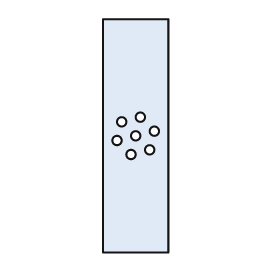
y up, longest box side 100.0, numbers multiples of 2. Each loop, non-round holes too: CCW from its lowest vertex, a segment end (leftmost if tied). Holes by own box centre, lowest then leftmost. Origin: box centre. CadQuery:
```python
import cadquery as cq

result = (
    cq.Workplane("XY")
    .moveTo(-14.0, -50.0)
    .lineTo(14.0, -50.0)
    .lineTo(14.0, 50.0)
    .lineTo(-14.0, 50.0)
    .close()
    .moveTo(-2.0, -8.0)
    .circle(2.0)
    .moveTo(6.0, -6.0)
    .circle(2.0)
    .moveTo(-8.0, -2.0)
    .circle(2.0)
    .moveTo(0.0, 0.0)
    .circle(2.0)
    .moveTo(8.0, 2.0)
    .circle(2.0)
    .moveTo(-6.0, 6.0)
    .circle(2.0)
    .moveTo(2.0, 8.0)
    .circle(2.0)
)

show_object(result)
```